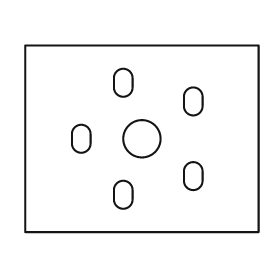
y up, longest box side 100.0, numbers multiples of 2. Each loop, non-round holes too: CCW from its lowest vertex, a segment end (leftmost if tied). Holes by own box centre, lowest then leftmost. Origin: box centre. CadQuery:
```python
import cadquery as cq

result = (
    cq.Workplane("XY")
    .moveTo(-50.0, -40.0)
    .lineTo(50.0, -40.0)
    .lineTo(50.0, 40.0)
    .lineTo(-50.0, 40.0)
    .close()
    .moveTo(-12.0, -26.0)
    .threePointArc((-8.0, -30.0), (-4.0, -26.0))
    .lineTo(-4.0, -22.0)
    .threePointArc((-8.0, -18.0), (-12.0, -22.0))
    .close()
    .moveTo(18.0, -18.0)
    .threePointArc((22.0, -22.0), (26.0, -18.0))
    .lineTo(26.0, -14.0)
    .threePointArc((22.0, -10.0), (18.0, -14.0))
    .close()
    .moveTo(-30.0, -2.0)
    .threePointArc((-26.0, -6.0), (-22.0, -2.0))
    .lineTo(-22.0, 2.0)
    .threePointArc((-26.0, 6.0), (-30.0, 2.0))
    .close()
    .moveTo(0.0, 0.0)
    .circle(8.0)
    .moveTo(18.0, 14.0)
    .threePointArc((22.0, 10.0), (26.0, 14.0))
    .lineTo(26.0, 18.0)
    .threePointArc((22.0, 22.0), (18.0, 18.0))
    .close()
    .moveTo(-12.0, 22.0)
    .threePointArc((-8.0, 18.0), (-4.0, 22.0))
    .lineTo(-4.0, 26.0)
    .threePointArc((-8.0, 30.0), (-12.0, 26.0))
    .close()
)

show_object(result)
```